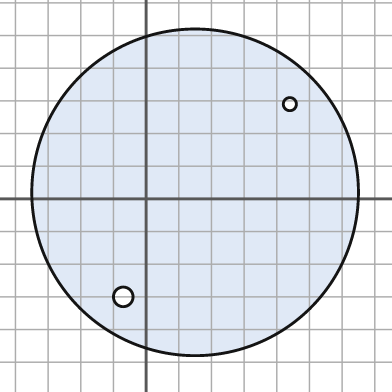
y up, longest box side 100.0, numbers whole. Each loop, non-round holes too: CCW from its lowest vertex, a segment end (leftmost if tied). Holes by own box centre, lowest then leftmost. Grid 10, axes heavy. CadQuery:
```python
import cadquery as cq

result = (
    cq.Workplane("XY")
    .moveTo(15.0, 2.0)
    .circle(50.0)
    .moveTo(-7.0, -30.0)
    .circle(3.0)
    .moveTo(44.0, 29.0)
    .circle(2.0)
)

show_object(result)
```